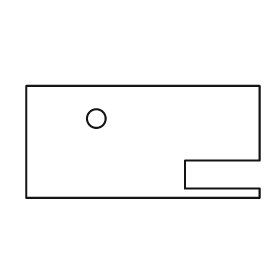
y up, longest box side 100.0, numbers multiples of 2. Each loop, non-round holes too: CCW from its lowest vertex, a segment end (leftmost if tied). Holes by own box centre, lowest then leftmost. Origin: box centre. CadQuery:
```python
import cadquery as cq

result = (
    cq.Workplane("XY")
    .moveTo(-50.0, -24.0)
    .lineTo(50.0, -24.0)
    .lineTo(50.0, -20.0)
    .lineTo(18.0, -20.0)
    .lineTo(18.0, -8.0)
    .lineTo(50.0, -8.0)
    .lineTo(50.0, 24.0)
    .lineTo(-50.0, 24.0)
    .close()
    .moveTo(-20.0, 10.0)
    .circle(4.0)
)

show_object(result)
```